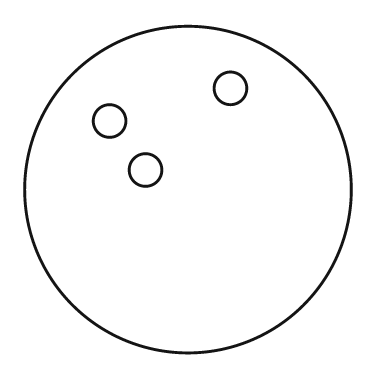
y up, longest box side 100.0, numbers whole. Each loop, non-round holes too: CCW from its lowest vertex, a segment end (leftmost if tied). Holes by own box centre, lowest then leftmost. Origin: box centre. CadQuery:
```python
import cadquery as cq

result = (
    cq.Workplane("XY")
    .moveTo(0.0, 0.0)
    .circle(50.0)
    .moveTo(-13.0, 6.0)
    .circle(5.0)
    .moveTo(-24.0, 21.0)
    .circle(5.0)
    .moveTo(13.0, 31.0)
    .circle(5.0)
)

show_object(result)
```